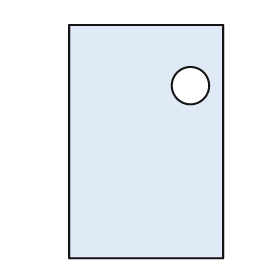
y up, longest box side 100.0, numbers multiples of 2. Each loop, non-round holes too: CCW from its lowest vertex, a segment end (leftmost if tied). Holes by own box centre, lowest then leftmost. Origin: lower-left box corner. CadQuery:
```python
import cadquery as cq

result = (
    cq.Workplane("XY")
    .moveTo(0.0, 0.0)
    .lineTo(66.0, 0.0)
    .lineTo(66.0, 100.0)
    .lineTo(0.0, 100.0)
    .close()
    .moveTo(52.0, 74.0)
    .circle(8.0)
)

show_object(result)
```